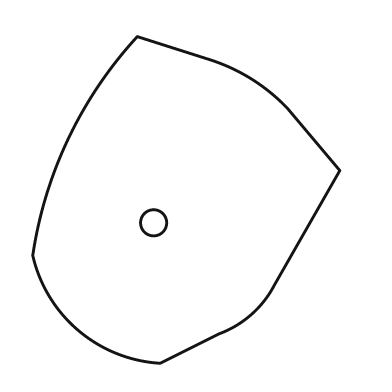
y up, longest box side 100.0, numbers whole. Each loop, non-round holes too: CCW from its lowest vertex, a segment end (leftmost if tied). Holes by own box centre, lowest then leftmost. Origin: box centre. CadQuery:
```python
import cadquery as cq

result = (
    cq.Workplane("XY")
    .moveTo(-8.0, -50.0)
    .lineTo(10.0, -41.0)
    .threePointArc((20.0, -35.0), (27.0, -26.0))
    .lineTo(47.0, 9.0)
    .lineTo(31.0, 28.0)
    .threePointArc((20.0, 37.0), (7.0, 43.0))
    .lineTo(-15.0, 50.0)
    .threePointArc((-36.0, 19.0), (-47.0, -17.0))
    .threePointArc((-33.0, -40.0), (-8.0, -50.0))
    .close()
    .moveTo(-10.0, -7.0)
    .circle(4.0)
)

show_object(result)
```